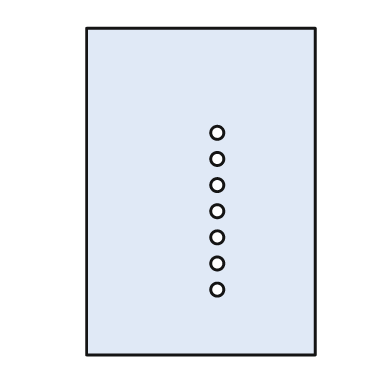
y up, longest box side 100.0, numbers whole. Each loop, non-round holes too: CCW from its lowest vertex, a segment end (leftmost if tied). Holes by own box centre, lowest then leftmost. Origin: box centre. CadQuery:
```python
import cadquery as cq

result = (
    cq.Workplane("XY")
    .moveTo(-35.0, -50.0)
    .lineTo(35.0, -50.0)
    .lineTo(35.0, 50.0)
    .lineTo(-35.0, 50.0)
    .close()
    .moveTo(5.0, -30.0)
    .circle(2.0)
    .moveTo(5.0, -22.0)
    .circle(2.0)
    .moveTo(5.0, -14.0)
    .circle(2.0)
    .moveTo(5.0, -6.0)
    .circle(2.0)
    .moveTo(5.0, 2.0)
    .circle(2.0)
    .moveTo(5.0, 10.0)
    .circle(2.0)
    .moveTo(5.0, 18.0)
    .circle(2.0)
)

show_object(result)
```